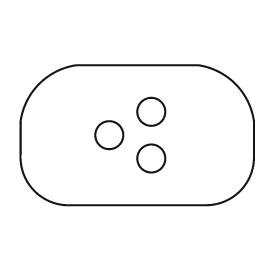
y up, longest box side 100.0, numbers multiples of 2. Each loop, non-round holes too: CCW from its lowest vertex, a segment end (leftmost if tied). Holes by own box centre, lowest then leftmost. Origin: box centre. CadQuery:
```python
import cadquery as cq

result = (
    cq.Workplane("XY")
    .moveTo(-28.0, -30.0)
    .lineTo(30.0, -30.0)
    .threePointArc((44.0, -24.0), (50.0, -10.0))
    .lineTo(50.0, 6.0)
    .threePointArc((42.0, 22.0), (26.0, 30.0))
    .lineTo(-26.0, 30.0)
    .threePointArc((-42.0, 22.0), (-50.0, 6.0))
    .lineTo(-50.0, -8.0)
    .threePointArc((-44.0, -24.0), (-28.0, -30.0))
    .close()
    .moveTo(6.0, -10.0)
    .circle(6.0)
    .moveTo(-12.0, 0.0)
    .circle(6.0)
    .moveTo(6.0, 10.0)
    .circle(6.0)
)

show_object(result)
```